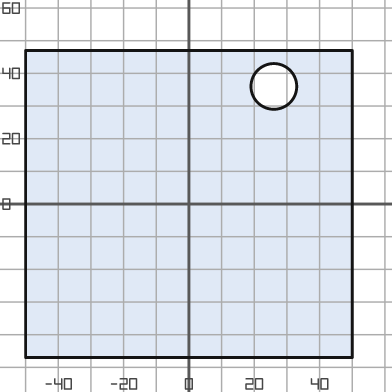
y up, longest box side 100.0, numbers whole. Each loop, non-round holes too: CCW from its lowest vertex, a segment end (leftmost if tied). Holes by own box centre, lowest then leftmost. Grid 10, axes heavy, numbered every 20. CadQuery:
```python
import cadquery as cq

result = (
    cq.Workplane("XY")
    .moveTo(-50.0, -47.0)
    .lineTo(50.0, -47.0)
    .lineTo(50.0, 47.0)
    .lineTo(-50.0, 47.0)
    .close()
    .moveTo(26.0, 36.0)
    .circle(7.0)
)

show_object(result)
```